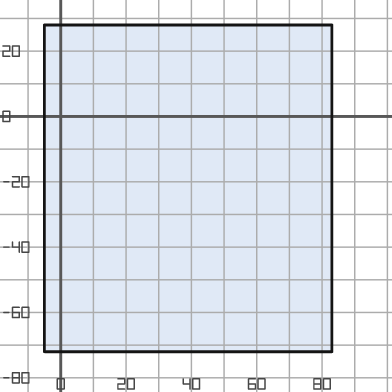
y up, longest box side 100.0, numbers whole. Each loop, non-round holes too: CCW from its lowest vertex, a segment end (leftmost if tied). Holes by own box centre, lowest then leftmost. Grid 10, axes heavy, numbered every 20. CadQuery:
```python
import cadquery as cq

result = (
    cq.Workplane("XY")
    .moveTo(-5.0, -72.0)
    .lineTo(83.0, -72.0)
    .lineTo(83.0, 28.0)
    .lineTo(-5.0, 28.0)
    .close()
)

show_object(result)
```